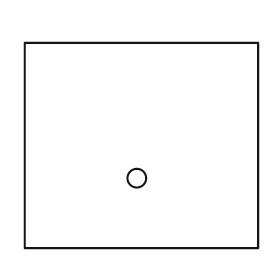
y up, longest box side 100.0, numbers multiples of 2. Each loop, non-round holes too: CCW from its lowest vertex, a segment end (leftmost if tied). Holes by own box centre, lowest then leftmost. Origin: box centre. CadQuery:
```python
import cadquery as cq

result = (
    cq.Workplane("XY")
    .moveTo(-50.0, -44.0)
    .lineTo(50.0, -44.0)
    .lineTo(50.0, 44.0)
    .lineTo(-50.0, 44.0)
    .close()
    .moveTo(-2.0, -14.0)
    .circle(4.0)
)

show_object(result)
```